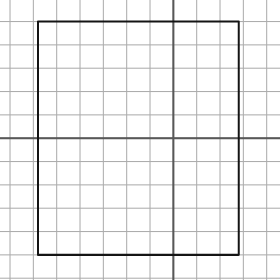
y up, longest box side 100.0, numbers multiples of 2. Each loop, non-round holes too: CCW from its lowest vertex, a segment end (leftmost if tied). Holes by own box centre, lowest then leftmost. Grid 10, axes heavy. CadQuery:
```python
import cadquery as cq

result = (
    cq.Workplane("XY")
    .moveTo(-58.0, -50.0)
    .lineTo(28.0, -50.0)
    .lineTo(28.0, 50.0)
    .lineTo(-58.0, 50.0)
    .close()
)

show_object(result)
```